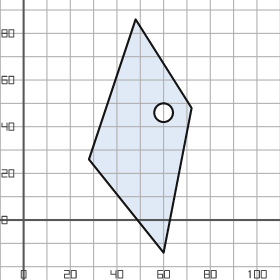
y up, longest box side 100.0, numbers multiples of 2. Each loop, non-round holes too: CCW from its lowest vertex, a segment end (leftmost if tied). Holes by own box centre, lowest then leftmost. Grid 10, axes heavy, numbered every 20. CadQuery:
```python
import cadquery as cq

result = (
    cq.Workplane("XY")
    .moveTo(60.0, -14.0)
    .lineTo(72.0, 48.0)
    .lineTo(48.0, 86.0)
    .lineTo(28.0, 26.0)
    .close()
    .moveTo(60.0, 46.0)
    .circle(4.0)
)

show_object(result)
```